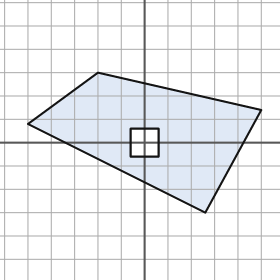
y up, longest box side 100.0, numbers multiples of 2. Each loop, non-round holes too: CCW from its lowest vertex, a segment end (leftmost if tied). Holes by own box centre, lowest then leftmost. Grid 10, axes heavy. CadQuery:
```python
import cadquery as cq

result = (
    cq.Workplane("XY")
    .moveTo(26.0, -30.0)
    .lineTo(50.0, 14.0)
    .lineTo(-20.0, 30.0)
    .lineTo(-50.0, 8.0)
    .close()
    .moveTo(-6.0, -6.0)
    .lineTo(6.0, -6.0)
    .lineTo(6.0, 6.0)
    .lineTo(-6.0, 6.0)
    .close()
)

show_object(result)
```